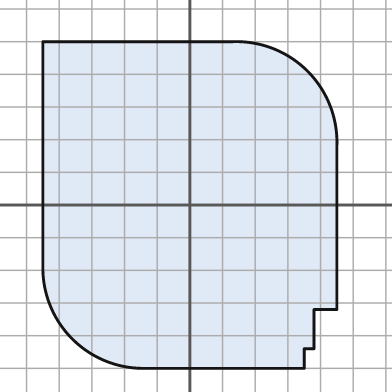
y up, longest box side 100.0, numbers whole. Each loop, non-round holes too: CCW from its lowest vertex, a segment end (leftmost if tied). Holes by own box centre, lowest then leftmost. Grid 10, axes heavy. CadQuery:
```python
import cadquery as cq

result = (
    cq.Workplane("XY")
    .moveTo(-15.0, -50.0)
    .lineTo(35.0, -50.0)
    .lineTo(35.0, -44.0)
    .lineTo(38.0, -44.0)
    .lineTo(38.0, -32.0)
    .lineTo(45.0, -32.0)
    .lineTo(45.0, 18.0)
    .threePointArc((36.0, 41.0), (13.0, 50.0))
    .lineTo(-45.0, 50.0)
    .lineTo(-45.0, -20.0)
    .threePointArc((-36.0, -41.0), (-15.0, -50.0))
    .close()
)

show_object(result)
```